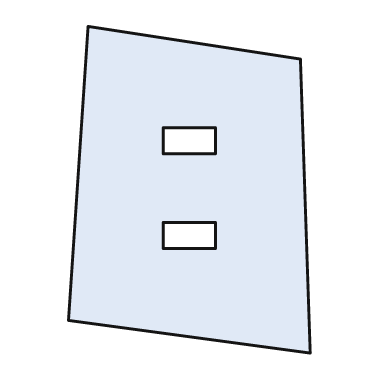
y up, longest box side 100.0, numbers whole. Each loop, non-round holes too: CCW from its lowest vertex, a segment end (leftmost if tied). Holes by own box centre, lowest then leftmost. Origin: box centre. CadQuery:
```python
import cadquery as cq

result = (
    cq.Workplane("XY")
    .moveTo(37.0, -50.0)
    .lineTo(34.0, 40.0)
    .lineTo(-31.0, 50.0)
    .lineTo(-37.0, -40.0)
    .close()
    .moveTo(-8.0, -18.0)
    .lineTo(8.0, -18.0)
    .lineTo(8.0, -10.0)
    .lineTo(-8.0, -10.0)
    .close()
    .moveTo(-8.0, 11.0)
    .lineTo(8.0, 11.0)
    .lineTo(8.0, 19.0)
    .lineTo(-8.0, 19.0)
    .close()
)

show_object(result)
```